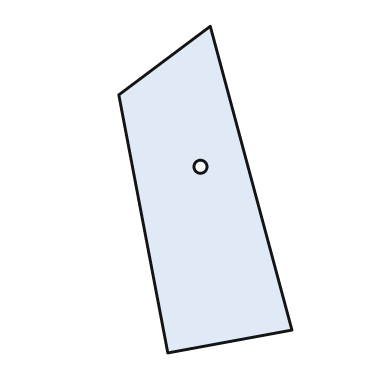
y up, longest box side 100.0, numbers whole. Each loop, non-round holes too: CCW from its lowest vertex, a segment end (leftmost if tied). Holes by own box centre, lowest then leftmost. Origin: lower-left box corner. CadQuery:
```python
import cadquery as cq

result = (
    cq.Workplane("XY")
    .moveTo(15.0, 0.0)
    .lineTo(53.0, 7.0)
    .lineTo(28.0, 100.0)
    .lineTo(0.0, 79.0)
    .close()
    .moveTo(25.0, 57.0)
    .circle(2.0)
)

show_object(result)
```